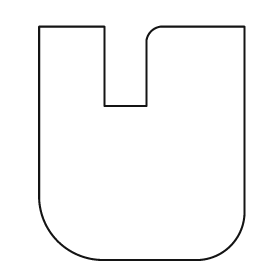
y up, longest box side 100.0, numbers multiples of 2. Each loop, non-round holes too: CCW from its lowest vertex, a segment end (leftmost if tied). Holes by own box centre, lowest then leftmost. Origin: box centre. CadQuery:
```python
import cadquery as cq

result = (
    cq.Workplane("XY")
    .moveTo(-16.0, -50.0)
    .lineTo(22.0, -50.0)
    .threePointArc((38.0, -44.0), (44.0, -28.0))
    .lineTo(44.0, 50.0)
    .lineTo(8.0, 50.0)
    .threePointArc((4.0, 48.0), (2.0, 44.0))
    .lineTo(2.0, 16.0)
    .lineTo(-16.0, 16.0)
    .lineTo(-16.0, 50.0)
    .lineTo(-44.0, 50.0)
    .lineTo(-44.0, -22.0)
    .threePointArc((-36.0, -42.0), (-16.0, -50.0))
    .close()
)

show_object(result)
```